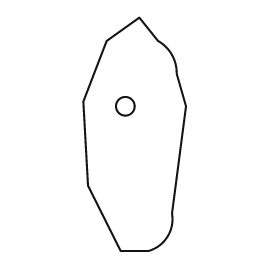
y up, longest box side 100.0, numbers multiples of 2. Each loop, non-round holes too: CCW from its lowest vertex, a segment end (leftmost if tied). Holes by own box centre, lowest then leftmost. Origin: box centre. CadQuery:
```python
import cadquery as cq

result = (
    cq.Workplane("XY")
    .moveTo(-6.0, -50.0)
    .lineTo(6.0, -50.0)
    .threePointArc((14.0, -44.0), (16.0, -34.0))
    .lineTo(22.0, 12.0)
    .lineTo(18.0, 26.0)
    .threePointArc((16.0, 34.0), (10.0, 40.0))
    .lineTo(2.0, 50.0)
    .lineTo(-12.0, 40.0)
    .lineTo(-22.0, 14.0)
    .lineTo(-20.0, -22.0)
    .close()
    .moveTo(-4.0, 12.0)
    .circle(4.0)
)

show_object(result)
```